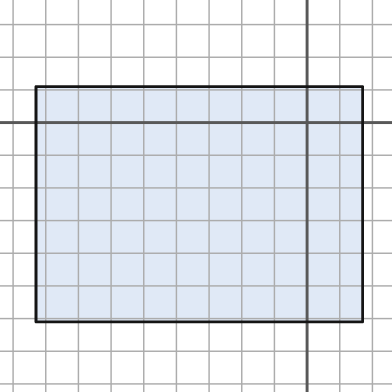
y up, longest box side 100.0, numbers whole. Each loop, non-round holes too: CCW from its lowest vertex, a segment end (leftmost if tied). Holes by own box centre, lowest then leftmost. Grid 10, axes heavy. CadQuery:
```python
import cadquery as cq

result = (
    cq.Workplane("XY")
    .moveTo(-83.0, -61.0)
    .lineTo(17.0, -61.0)
    .lineTo(17.0, 11.0)
    .lineTo(-83.0, 11.0)
    .close()
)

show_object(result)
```